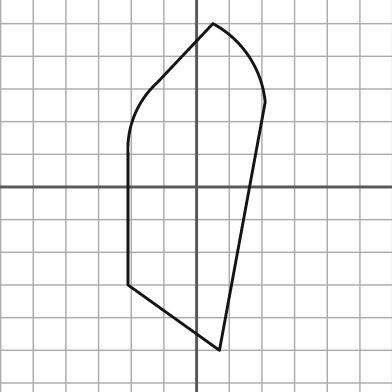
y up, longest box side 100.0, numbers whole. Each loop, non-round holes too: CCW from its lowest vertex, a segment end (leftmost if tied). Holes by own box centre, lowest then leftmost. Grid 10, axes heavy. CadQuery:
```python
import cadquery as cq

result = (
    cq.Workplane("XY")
    .moveTo(7.0, -50.0)
    .lineTo(21.0, 26.0)
    .threePointArc((16.0, 40.0), (5.0, 50.0))
    .lineTo(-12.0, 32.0)
    .threePointArc((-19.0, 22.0), (-21.0, 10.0))
    .lineTo(-21.0, -30.0)
    .close()
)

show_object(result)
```